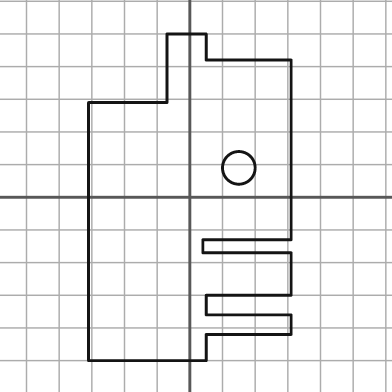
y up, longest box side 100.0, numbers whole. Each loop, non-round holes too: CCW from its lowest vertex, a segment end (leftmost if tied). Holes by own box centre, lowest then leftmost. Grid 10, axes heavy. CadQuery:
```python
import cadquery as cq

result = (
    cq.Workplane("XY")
    .moveTo(-31.0, -50.0)
    .lineTo(5.0, -50.0)
    .lineTo(5.0, -42.0)
    .lineTo(31.0, -42.0)
    .lineTo(31.0, -36.0)
    .lineTo(5.0, -36.0)
    .lineTo(5.0, -30.0)
    .lineTo(31.0, -30.0)
    .lineTo(31.0, -17.0)
    .lineTo(4.0, -17.0)
    .lineTo(4.0, -13.0)
    .lineTo(31.0, -13.0)
    .lineTo(31.0, 42.0)
    .lineTo(5.0, 42.0)
    .lineTo(5.0, 50.0)
    .lineTo(-7.0, 50.0)
    .lineTo(-7.0, 29.0)
    .lineTo(-31.0, 29.0)
    .close()
    .moveTo(15.0, 9.0)
    .circle(5.0)
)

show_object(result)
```